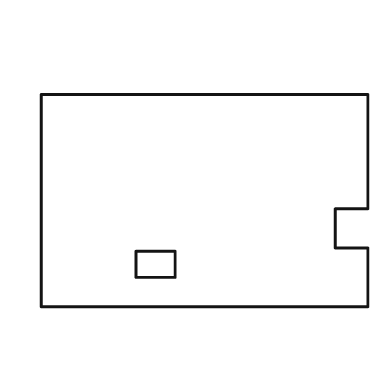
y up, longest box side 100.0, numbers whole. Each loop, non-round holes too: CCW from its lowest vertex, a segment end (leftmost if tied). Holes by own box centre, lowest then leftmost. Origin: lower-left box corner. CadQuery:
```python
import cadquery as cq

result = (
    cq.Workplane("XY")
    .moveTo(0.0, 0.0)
    .lineTo(100.0, 0.0)
    .lineTo(100.0, 18.0)
    .lineTo(90.0, 18.0)
    .lineTo(90.0, 30.0)
    .lineTo(100.0, 30.0)
    .lineTo(100.0, 65.0)
    .lineTo(0.0, 65.0)
    .close()
    .moveTo(29.0, 9.0)
    .lineTo(41.0, 9.0)
    .lineTo(41.0, 17.0)
    .lineTo(29.0, 17.0)
    .close()
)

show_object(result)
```